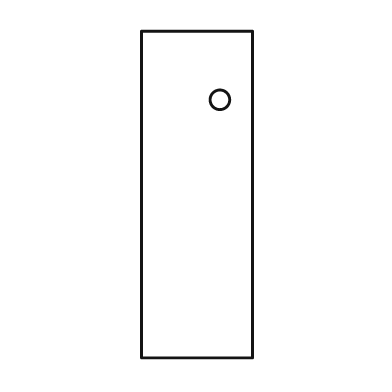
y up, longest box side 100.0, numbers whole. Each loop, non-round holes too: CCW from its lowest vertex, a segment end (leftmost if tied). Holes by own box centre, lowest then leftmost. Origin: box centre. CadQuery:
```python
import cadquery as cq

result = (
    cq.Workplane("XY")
    .moveTo(-17.0, -50.0)
    .lineTo(17.0, -50.0)
    .lineTo(17.0, 50.0)
    .lineTo(-17.0, 50.0)
    .close()
    .moveTo(7.0, 29.0)
    .circle(3.0)
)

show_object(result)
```